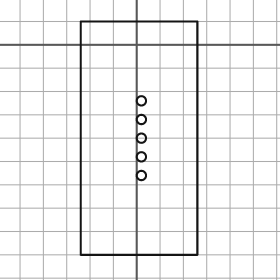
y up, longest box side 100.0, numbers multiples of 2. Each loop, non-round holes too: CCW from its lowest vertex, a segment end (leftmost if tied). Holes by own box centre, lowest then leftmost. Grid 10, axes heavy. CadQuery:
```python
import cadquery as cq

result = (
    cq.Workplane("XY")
    .moveTo(-24.0, -90.0)
    .lineTo(26.0, -90.0)
    .lineTo(26.0, 10.0)
    .lineTo(-24.0, 10.0)
    .close()
    .moveTo(2.0, -56.0)
    .circle(2.0)
    .moveTo(2.0, -48.0)
    .circle(2.0)
    .moveTo(2.0, -40.0)
    .circle(2.0)
    .moveTo(2.0, -32.0)
    .circle(2.0)
    .moveTo(2.0, -24.0)
    .circle(2.0)
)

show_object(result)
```